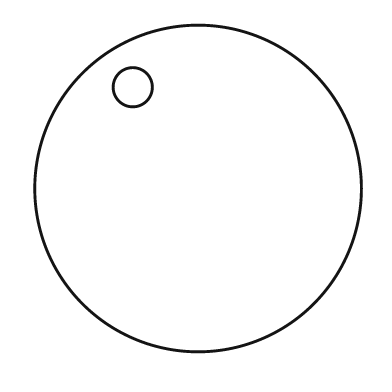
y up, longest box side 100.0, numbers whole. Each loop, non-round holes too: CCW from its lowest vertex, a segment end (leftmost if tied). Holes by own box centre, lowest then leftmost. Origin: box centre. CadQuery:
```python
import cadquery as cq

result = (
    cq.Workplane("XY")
    .moveTo(0.0, 0.0)
    .circle(50.0)
    .moveTo(-20.0, 31.0)
    .circle(6.0)
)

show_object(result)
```